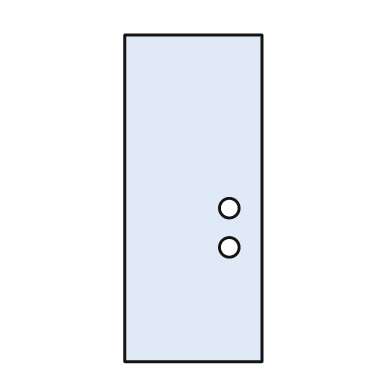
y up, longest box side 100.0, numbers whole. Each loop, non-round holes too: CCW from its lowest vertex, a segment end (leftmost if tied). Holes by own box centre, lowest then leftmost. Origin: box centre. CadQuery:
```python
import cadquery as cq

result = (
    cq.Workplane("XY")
    .moveTo(-21.0, -50.0)
    .lineTo(21.0, -50.0)
    .lineTo(21.0, 50.0)
    .lineTo(-21.0, 50.0)
    .close()
    .moveTo(11.0, -15.0)
    .circle(3.0)
    .moveTo(11.0, -3.0)
    .circle(3.0)
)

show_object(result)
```